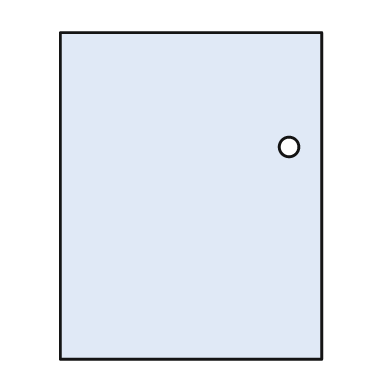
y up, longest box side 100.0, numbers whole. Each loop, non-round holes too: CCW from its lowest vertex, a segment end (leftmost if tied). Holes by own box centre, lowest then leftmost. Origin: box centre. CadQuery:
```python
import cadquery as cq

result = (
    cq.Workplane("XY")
    .moveTo(-40.0, -50.0)
    .lineTo(40.0, -50.0)
    .lineTo(40.0, 50.0)
    .lineTo(-40.0, 50.0)
    .close()
    .moveTo(30.0, 15.0)
    .circle(3.0)
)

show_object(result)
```